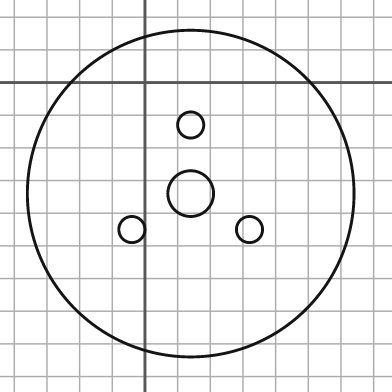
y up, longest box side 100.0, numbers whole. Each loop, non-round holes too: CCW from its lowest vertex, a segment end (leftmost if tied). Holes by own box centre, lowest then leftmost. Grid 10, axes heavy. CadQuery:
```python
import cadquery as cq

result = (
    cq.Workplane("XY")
    .moveTo(14.0, -34.0)
    .circle(50.0)
    .moveTo(-4.0, -45.0)
    .circle(4.0)
    .moveTo(32.0, -45.0)
    .circle(4.0)
    .moveTo(14.0, -34.0)
    .circle(7.0)
    .moveTo(14.0, -13.0)
    .circle(4.0)
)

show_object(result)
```